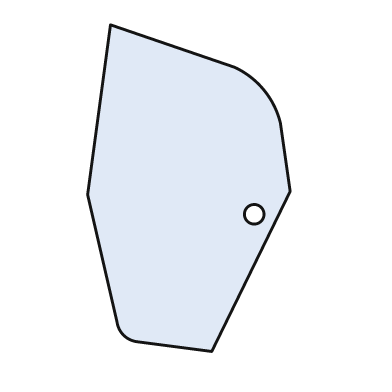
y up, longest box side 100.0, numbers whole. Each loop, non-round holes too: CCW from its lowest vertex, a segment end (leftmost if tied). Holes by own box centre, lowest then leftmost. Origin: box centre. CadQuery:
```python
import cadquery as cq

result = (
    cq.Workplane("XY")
    .moveTo(7.0, -50.0)
    .lineTo(31.0, -1.0)
    .lineTo(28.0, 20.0)
    .threePointArc((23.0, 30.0), (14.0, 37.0))
    .lineTo(-24.0, 50.0)
    .lineTo(-31.0, -2.0)
    .lineTo(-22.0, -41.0)
    .threePointArc((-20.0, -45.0), (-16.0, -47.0))
    .close()
    .moveTo(20.0, -8.0)
    .circle(3.0)
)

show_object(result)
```